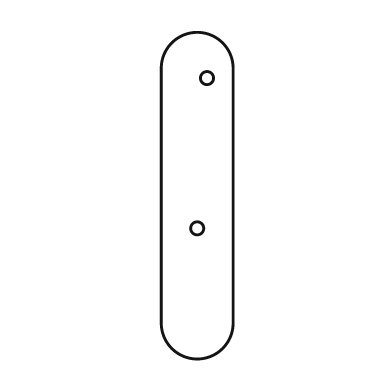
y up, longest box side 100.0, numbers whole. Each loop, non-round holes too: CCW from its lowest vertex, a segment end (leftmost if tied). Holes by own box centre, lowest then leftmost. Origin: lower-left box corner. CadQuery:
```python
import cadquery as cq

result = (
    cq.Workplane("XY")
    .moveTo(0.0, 11.0)
    .threePointArc((11.0, 0.0), (22.0, 11.0))
    .lineTo(22.0, 89.0)
    .threePointArc((11.0, 100.0), (0.0, 89.0))
    .close()
    .moveTo(11.0, 40.0)
    .circle(2.0)
    .moveTo(14.0, 86.0)
    .circle(2.0)
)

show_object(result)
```